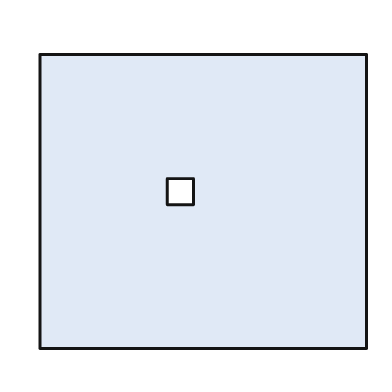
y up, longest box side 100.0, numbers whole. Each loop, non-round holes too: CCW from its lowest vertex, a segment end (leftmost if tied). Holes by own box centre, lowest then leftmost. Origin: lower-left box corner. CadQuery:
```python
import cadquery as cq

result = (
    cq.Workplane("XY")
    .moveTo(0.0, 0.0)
    .lineTo(100.0, 0.0)
    .lineTo(100.0, 90.0)
    .lineTo(0.0, 90.0)
    .close()
    .moveTo(39.0, 44.0)
    .lineTo(47.0, 44.0)
    .lineTo(47.0, 52.0)
    .lineTo(39.0, 52.0)
    .close()
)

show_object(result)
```